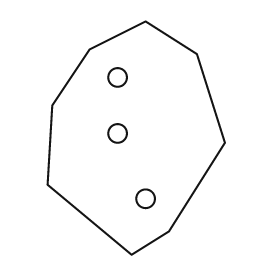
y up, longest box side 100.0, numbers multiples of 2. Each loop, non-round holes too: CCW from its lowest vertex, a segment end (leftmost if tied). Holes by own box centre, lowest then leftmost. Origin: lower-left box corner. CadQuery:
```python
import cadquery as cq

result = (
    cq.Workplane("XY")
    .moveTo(36.0, 0.0)
    .lineTo(52.0, 10.0)
    .lineTo(76.0, 48.0)
    .lineTo(64.0, 86.0)
    .lineTo(42.0, 100.0)
    .lineTo(18.0, 88.0)
    .lineTo(2.0, 64.0)
    .lineTo(0.0, 30.0)
    .close()
    .moveTo(42.0, 24.0)
    .circle(4.0)
    .moveTo(30.0, 52.0)
    .circle(4.0)
    .moveTo(30.0, 76.0)
    .circle(4.0)
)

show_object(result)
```